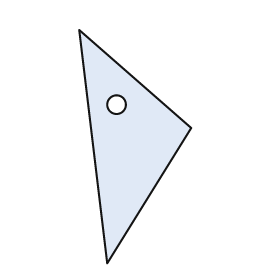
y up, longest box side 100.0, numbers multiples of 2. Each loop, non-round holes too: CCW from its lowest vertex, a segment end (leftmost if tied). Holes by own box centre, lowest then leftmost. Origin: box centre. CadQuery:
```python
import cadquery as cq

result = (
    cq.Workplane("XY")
    .moveTo(-12.0, -50.0)
    .lineTo(24.0, 8.0)
    .lineTo(-24.0, 50.0)
    .close()
    .moveTo(-8.0, 18.0)
    .circle(4.0)
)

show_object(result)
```